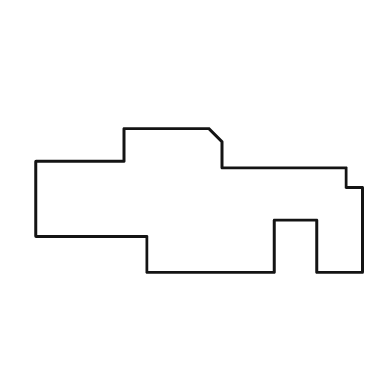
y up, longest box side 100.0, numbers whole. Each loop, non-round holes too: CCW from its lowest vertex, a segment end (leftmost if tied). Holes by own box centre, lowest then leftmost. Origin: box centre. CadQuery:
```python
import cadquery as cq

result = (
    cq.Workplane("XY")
    .moveTo(-16.0, -22.0)
    .lineTo(23.0, -22.0)
    .lineTo(23.0, -6.0)
    .lineTo(36.0, -6.0)
    .lineTo(36.0, -22.0)
    .lineTo(50.0, -22.0)
    .lineTo(50.0, 4.0)
    .lineTo(45.0, 4.0)
    .lineTo(45.0, 10.0)
    .lineTo(7.0, 10.0)
    .lineTo(7.0, 18.0)
    .lineTo(3.0, 22.0)
    .lineTo(-23.0, 22.0)
    .lineTo(-23.0, 12.0)
    .lineTo(-50.0, 12.0)
    .lineTo(-50.0, -11.0)
    .lineTo(-16.0, -11.0)
    .close()
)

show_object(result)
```